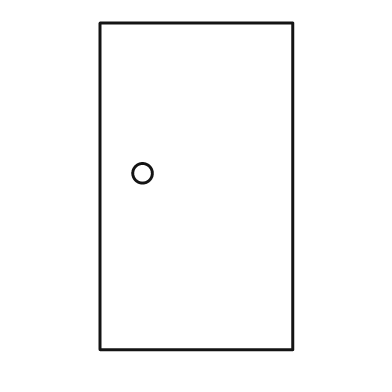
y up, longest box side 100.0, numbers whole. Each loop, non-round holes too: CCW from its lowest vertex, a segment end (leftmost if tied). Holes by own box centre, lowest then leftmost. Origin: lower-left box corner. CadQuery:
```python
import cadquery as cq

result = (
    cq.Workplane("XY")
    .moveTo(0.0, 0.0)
    .lineTo(59.0, 0.0)
    .lineTo(59.0, 100.0)
    .lineTo(0.0, 100.0)
    .close()
    .moveTo(13.0, 54.0)
    .circle(3.0)
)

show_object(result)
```